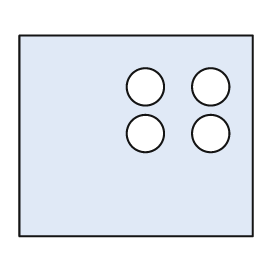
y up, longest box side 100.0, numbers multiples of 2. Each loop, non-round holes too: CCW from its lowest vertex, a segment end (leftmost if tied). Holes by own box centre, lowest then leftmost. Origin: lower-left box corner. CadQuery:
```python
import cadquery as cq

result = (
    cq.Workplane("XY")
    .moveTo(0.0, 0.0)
    .lineTo(100.0, 0.0)
    .lineTo(100.0, 86.0)
    .lineTo(0.0, 86.0)
    .close()
    .moveTo(54.0, 44.0)
    .circle(8.0)
    .moveTo(82.0, 44.0)
    .circle(8.0)
    .moveTo(54.0, 64.0)
    .circle(8.0)
    .moveTo(82.0, 64.0)
    .circle(8.0)
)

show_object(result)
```